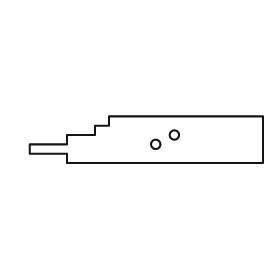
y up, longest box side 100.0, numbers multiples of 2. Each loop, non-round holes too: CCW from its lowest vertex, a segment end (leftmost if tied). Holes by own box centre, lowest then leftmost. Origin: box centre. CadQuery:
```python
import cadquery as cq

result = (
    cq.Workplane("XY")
    .moveTo(-34.0, -10.0)
    .lineTo(50.0, -10.0)
    .lineTo(50.0, 10.0)
    .lineTo(-16.0, 10.0)
    .lineTo(-16.0, 6.0)
    .lineTo(-22.0, 6.0)
    .lineTo(-22.0, 2.0)
    .lineTo(-34.0, 2.0)
    .lineTo(-34.0, -2.0)
    .lineTo(-50.0, -2.0)
    .lineTo(-50.0, -6.0)
    .lineTo(-34.0, -6.0)
    .close()
    .moveTo(4.0, -2.0)
    .circle(2.0)
    .moveTo(12.0, 2.0)
    .circle(2.0)
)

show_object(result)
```